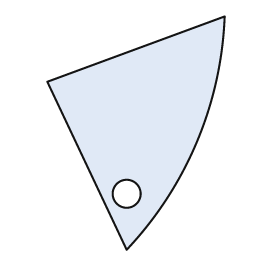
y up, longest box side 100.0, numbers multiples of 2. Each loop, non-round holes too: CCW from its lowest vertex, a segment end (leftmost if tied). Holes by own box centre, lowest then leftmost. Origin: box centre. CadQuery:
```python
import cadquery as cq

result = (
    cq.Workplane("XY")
    .moveTo(-4.0, -50.0)
    .threePointArc((26.0, -4.0), (38.0, 50.0))
    .lineTo(-38.0, 22.0)
    .close()
    .moveTo(-4.0, -26.0)
    .circle(6.0)
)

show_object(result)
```